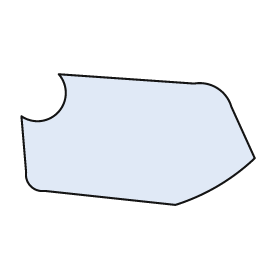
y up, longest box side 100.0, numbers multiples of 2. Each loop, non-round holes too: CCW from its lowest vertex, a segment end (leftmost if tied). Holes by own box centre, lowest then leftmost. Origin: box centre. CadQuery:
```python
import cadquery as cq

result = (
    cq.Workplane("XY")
    .moveTo(16.0, -28.0)
    .threePointArc((34.0, -20.0), (50.0, -8.0))
    .lineTo(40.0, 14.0)
    .threePointArc((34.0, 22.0), (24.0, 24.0))
    .lineTo(-34.0, 28.0)
    .threePointArc((-34.0, 12.0), (-50.0, 10.0))
    .lineTo(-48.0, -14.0)
    .threePointArc((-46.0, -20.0), (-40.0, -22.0))
    .close()
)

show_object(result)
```